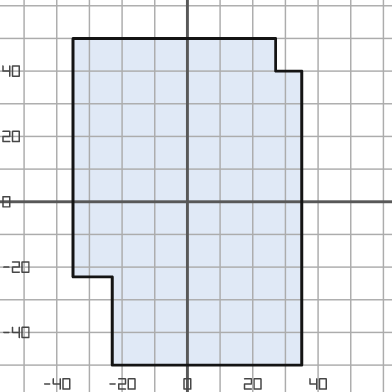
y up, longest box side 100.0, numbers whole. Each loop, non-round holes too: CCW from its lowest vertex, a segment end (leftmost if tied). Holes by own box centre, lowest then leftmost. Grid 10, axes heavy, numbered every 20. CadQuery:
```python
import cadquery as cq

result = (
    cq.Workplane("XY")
    .moveTo(-23.0, -50.0)
    .lineTo(35.0, -50.0)
    .lineTo(35.0, 40.0)
    .lineTo(27.0, 40.0)
    .lineTo(27.0, 50.0)
    .lineTo(-35.0, 50.0)
    .lineTo(-35.0, -23.0)
    .lineTo(-23.0, -23.0)
    .close()
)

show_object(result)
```